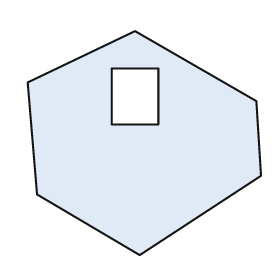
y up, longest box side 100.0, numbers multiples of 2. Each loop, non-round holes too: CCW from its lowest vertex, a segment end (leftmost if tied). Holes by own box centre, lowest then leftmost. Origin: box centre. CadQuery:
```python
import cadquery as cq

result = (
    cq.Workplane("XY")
    .moveTo(-2.0, -48.0)
    .lineTo(50.0, -14.0)
    .lineTo(48.0, 18.0)
    .lineTo(-4.0, 48.0)
    .lineTo(-50.0, 26.0)
    .lineTo(-46.0, -22.0)
    .close()
    .moveTo(-14.0, 8.0)
    .lineTo(6.0, 8.0)
    .lineTo(6.0, 32.0)
    .lineTo(-14.0, 32.0)
    .close()
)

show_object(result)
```